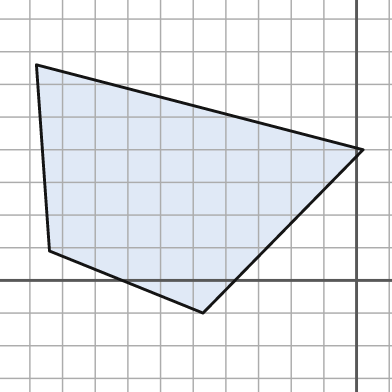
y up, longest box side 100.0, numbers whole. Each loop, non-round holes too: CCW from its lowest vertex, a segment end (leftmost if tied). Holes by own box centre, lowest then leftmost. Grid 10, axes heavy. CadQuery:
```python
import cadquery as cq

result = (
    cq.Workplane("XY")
    .moveTo(-47.0, -10.0)
    .lineTo(2.0, 40.0)
    .lineTo(-98.0, 66.0)
    .lineTo(-94.0, 9.0)
    .close()
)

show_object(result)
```